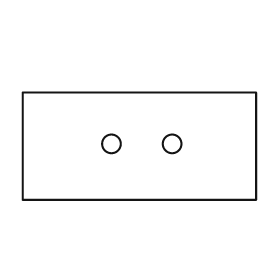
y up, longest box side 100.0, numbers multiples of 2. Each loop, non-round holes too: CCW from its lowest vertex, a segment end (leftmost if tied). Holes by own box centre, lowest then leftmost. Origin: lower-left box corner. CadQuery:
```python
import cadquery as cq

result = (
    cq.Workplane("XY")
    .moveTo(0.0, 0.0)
    .lineTo(100.0, 0.0)
    .lineTo(100.0, 46.0)
    .lineTo(0.0, 46.0)
    .close()
    .moveTo(38.0, 24.0)
    .circle(4.0)
    .moveTo(64.0, 24.0)
    .circle(4.0)
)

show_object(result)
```